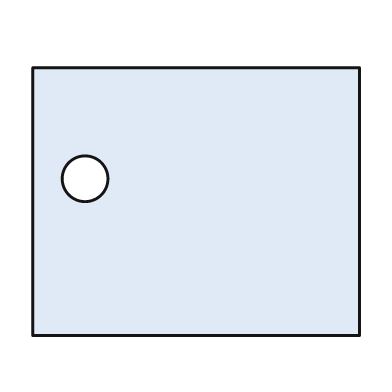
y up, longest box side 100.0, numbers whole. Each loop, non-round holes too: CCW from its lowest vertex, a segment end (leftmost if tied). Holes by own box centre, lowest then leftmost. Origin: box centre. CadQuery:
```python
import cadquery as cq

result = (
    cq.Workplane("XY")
    .moveTo(-50.0, -41.0)
    .lineTo(50.0, -41.0)
    .lineTo(50.0, 41.0)
    .lineTo(-50.0, 41.0)
    .close()
    .moveTo(-34.0, 7.0)
    .circle(7.0)
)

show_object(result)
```